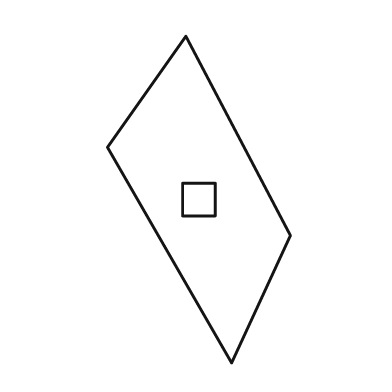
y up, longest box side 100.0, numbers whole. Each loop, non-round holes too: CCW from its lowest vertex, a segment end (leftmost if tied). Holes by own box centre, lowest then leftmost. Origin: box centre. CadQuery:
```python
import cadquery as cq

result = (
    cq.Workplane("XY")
    .moveTo(10.0, -50.0)
    .lineTo(28.0, -11.0)
    .lineTo(-4.0, 50.0)
    .lineTo(-28.0, 16.0)
    .close()
    .moveTo(-5.0, -5.0)
    .lineTo(5.0, -5.0)
    .lineTo(5.0, 5.0)
    .lineTo(-5.0, 5.0)
    .close()
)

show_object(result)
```